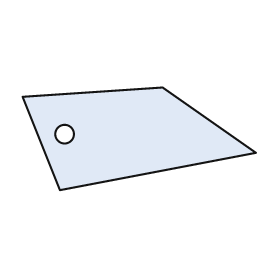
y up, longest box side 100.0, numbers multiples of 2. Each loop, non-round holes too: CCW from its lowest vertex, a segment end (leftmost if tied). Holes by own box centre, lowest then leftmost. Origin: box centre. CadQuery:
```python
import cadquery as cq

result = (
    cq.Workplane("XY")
    .moveTo(-34.0, -22.0)
    .lineTo(50.0, -6.0)
    .lineTo(10.0, 22.0)
    .lineTo(-50.0, 18.0)
    .close()
    .moveTo(-32.0, 2.0)
    .circle(4.0)
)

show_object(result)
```